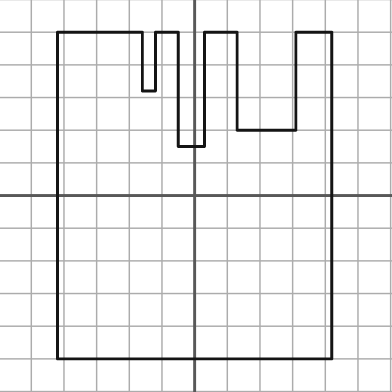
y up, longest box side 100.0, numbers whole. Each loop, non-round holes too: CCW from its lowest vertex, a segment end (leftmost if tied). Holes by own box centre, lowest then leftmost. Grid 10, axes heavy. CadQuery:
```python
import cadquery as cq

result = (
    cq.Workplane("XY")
    .moveTo(-42.0, -50.0)
    .lineTo(42.0, -50.0)
    .lineTo(42.0, 50.0)
    .lineTo(31.0, 50.0)
    .lineTo(31.0, 20.0)
    .lineTo(13.0, 20.0)
    .lineTo(13.0, 50.0)
    .lineTo(3.0, 50.0)
    .lineTo(3.0, 15.0)
    .lineTo(-5.0, 15.0)
    .lineTo(-5.0, 50.0)
    .lineTo(-12.0, 50.0)
    .lineTo(-12.0, 32.0)
    .lineTo(-16.0, 32.0)
    .lineTo(-16.0, 50.0)
    .lineTo(-42.0, 50.0)
    .close()
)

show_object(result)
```